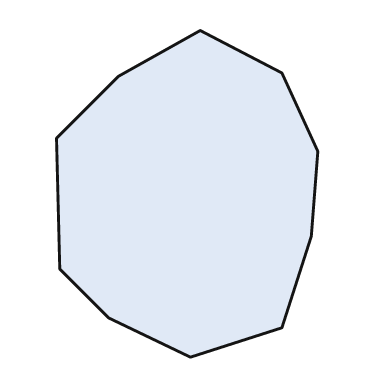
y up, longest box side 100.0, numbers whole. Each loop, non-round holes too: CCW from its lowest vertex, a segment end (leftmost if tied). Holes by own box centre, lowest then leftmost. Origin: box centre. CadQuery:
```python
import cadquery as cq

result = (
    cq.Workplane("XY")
    .moveTo(1.0, -50.0)
    .lineTo(29.0, -41.0)
    .lineTo(38.0, -13.0)
    .lineTo(40.0, 13.0)
    .lineTo(29.0, 37.0)
    .lineTo(4.0, 50.0)
    .lineTo(-21.0, 36.0)
    .lineTo(-40.0, 17.0)
    .lineTo(-39.0, -23.0)
    .lineTo(-24.0, -38.0)
    .close()
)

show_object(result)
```